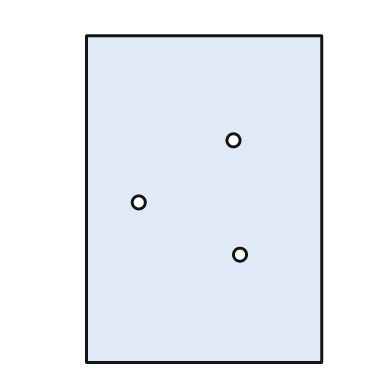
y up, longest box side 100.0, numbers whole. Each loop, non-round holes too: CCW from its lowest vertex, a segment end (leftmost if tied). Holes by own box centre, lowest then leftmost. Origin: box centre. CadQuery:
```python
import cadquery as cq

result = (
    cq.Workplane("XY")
    .moveTo(-36.0, -50.0)
    .lineTo(36.0, -50.0)
    .lineTo(36.0, 50.0)
    .lineTo(-36.0, 50.0)
    .close()
    .moveTo(11.0, -17.0)
    .circle(2.0)
    .moveTo(-20.0, -1.0)
    .circle(2.0)
    .moveTo(9.0, 18.0)
    .circle(2.0)
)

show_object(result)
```